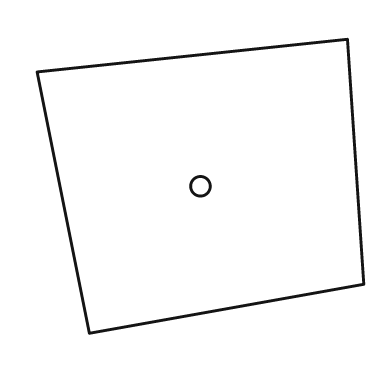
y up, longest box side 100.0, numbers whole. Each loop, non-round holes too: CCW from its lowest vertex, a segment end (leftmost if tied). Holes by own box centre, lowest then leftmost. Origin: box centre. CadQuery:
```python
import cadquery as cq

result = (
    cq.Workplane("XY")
    .moveTo(-34.0, -45.0)
    .lineTo(50.0, -30.0)
    .lineTo(45.0, 45.0)
    .lineTo(-50.0, 35.0)
    .close()
    .moveTo(0.0, 0.0)
    .circle(3.0)
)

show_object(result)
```